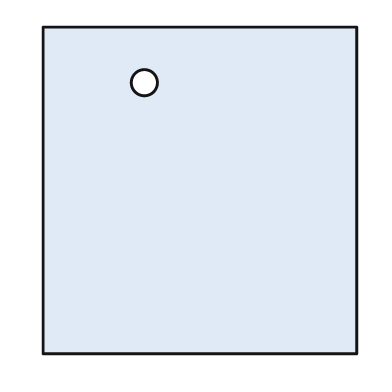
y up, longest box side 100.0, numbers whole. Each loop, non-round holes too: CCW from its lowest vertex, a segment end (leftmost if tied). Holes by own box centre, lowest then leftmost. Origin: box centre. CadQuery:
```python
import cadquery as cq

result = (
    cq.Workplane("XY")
    .moveTo(-48.0, -50.0)
    .lineTo(48.0, -50.0)
    .lineTo(48.0, 50.0)
    .lineTo(-48.0, 50.0)
    .close()
    .moveTo(-17.0, 33.0)
    .circle(4.0)
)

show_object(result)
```